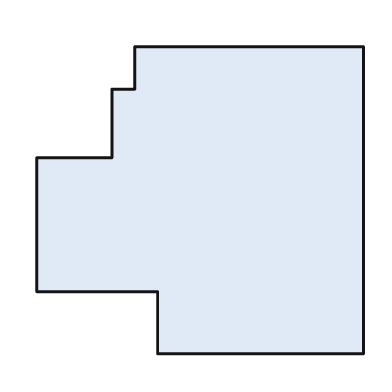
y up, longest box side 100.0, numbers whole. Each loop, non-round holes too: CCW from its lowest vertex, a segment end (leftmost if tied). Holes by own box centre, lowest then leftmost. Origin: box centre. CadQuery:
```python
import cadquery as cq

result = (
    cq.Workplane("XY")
    .moveTo(-13.0, -47.0)
    .lineTo(50.0, -47.0)
    .lineTo(50.0, 47.0)
    .lineTo(-20.0, 47.0)
    .lineTo(-20.0, 34.0)
    .lineTo(-27.0, 34.0)
    .lineTo(-27.0, 13.0)
    .lineTo(-50.0, 13.0)
    .lineTo(-50.0, -28.0)
    .lineTo(-13.0, -28.0)
    .close()
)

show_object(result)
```